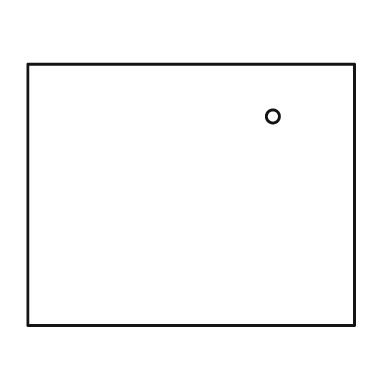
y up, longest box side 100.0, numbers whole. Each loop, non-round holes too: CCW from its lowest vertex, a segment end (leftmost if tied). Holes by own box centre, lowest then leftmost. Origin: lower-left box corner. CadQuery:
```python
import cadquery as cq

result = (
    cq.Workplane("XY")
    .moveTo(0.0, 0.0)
    .lineTo(100.0, 0.0)
    .lineTo(100.0, 80.0)
    .lineTo(0.0, 80.0)
    .close()
    .moveTo(75.0, 64.0)
    .circle(2.0)
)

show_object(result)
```